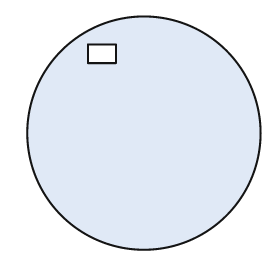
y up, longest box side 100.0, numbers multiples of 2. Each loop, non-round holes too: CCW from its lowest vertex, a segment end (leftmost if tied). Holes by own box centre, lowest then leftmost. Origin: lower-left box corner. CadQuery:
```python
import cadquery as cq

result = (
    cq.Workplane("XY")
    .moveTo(50.0, 50.0)
    .circle(50.0)
    .moveTo(26.0, 80.0)
    .lineTo(38.0, 80.0)
    .lineTo(38.0, 88.0)
    .lineTo(26.0, 88.0)
    .close()
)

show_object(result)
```